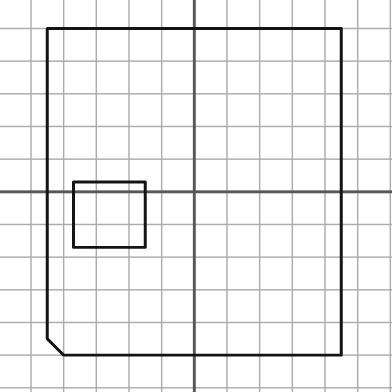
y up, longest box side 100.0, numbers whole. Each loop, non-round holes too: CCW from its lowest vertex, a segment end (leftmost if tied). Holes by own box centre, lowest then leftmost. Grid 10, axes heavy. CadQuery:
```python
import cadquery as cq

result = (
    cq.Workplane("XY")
    .moveTo(-40.0, -50.0)
    .lineTo(45.0, -50.0)
    .lineTo(45.0, 50.0)
    .lineTo(-45.0, 50.0)
    .lineTo(-45.0, -45.0)
    .close()
    .moveTo(-37.0, -17.0)
    .lineTo(-15.0, -17.0)
    .lineTo(-15.0, 3.0)
    .lineTo(-37.0, 3.0)
    .close()
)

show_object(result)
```